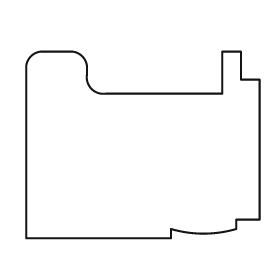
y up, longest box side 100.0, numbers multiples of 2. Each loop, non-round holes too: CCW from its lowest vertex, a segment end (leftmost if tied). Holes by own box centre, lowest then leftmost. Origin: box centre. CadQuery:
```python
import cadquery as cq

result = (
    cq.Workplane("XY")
    .moveTo(-50.0, -40.0)
    .lineTo(12.0, -40.0)
    .lineTo(12.0, -36.0)
    .threePointArc((26.0, -38.0), (40.0, -36.0))
    .lineTo(40.0, -32.0)
    .lineTo(50.0, -32.0)
    .lineTo(50.0, 28.0)
    .lineTo(42.0, 28.0)
    .lineTo(42.0, 40.0)
    .lineTo(34.0, 40.0)
    .lineTo(34.0, 22.0)
    .lineTo(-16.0, 22.0)
    .threePointArc((-22.0, 24.0), (-24.0, 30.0))
    .lineTo(-24.0, 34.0)
    .threePointArc((-26.0, 38.0), (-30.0, 40.0))
    .lineTo(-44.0, 40.0)
    .threePointArc((-48.0, 38.0), (-50.0, 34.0))
    .close()
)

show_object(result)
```